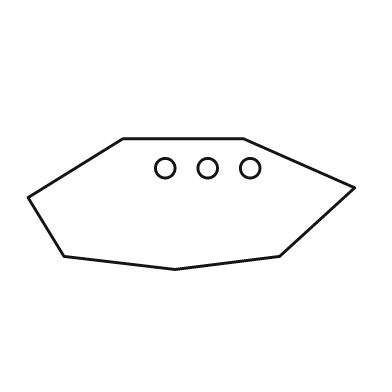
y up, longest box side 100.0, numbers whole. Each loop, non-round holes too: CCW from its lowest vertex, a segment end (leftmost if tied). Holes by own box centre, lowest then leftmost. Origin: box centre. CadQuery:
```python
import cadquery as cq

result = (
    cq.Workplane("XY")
    .moveTo(-5.0, -20.0)
    .lineTo(27.0, -16.0)
    .lineTo(50.0, 5.0)
    .lineTo(16.0, 20.0)
    .lineTo(-21.0, 20.0)
    .lineTo(-50.0, 2.0)
    .lineTo(-39.0, -16.0)
    .close()
    .moveTo(-8.0, 11.0)
    .circle(3.0)
    .moveTo(5.0, 11.0)
    .circle(3.0)
    .moveTo(18.0, 11.0)
    .circle(3.0)
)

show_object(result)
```